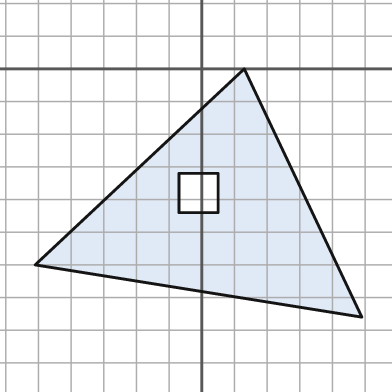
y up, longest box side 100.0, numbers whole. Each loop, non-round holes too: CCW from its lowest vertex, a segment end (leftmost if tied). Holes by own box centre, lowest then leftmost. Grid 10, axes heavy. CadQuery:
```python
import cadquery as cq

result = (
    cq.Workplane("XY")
    .moveTo(49.0, -76.0)
    .lineTo(13.0, 0.0)
    .lineTo(-51.0, -60.0)
    .close()
    .moveTo(-7.0, -44.0)
    .lineTo(5.0, -44.0)
    .lineTo(5.0, -32.0)
    .lineTo(-7.0, -32.0)
    .close()
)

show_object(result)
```